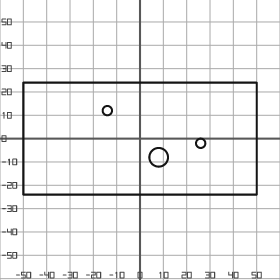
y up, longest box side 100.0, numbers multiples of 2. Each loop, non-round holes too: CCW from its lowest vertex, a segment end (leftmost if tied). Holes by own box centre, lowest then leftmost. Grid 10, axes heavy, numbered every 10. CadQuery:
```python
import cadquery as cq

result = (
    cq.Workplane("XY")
    .moveTo(-50.0, -24.0)
    .lineTo(50.0, -24.0)
    .lineTo(50.0, 24.0)
    .lineTo(-50.0, 24.0)
    .close()
    .moveTo(8.0, -8.0)
    .circle(4.0)
    .moveTo(26.0, -2.0)
    .circle(2.0)
    .moveTo(-14.0, 12.0)
    .circle(2.0)
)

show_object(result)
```